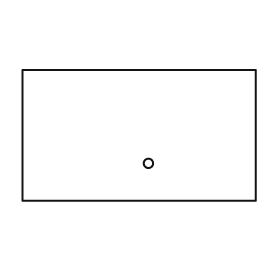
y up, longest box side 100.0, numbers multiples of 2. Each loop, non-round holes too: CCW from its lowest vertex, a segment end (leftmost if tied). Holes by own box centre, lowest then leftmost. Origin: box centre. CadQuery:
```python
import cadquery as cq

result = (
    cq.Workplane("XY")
    .moveTo(-50.0, -28.0)
    .lineTo(50.0, -28.0)
    .lineTo(50.0, 28.0)
    .lineTo(-50.0, 28.0)
    .close()
    .moveTo(4.0, -12.0)
    .circle(2.0)
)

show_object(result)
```